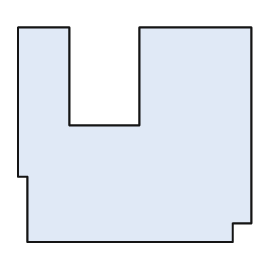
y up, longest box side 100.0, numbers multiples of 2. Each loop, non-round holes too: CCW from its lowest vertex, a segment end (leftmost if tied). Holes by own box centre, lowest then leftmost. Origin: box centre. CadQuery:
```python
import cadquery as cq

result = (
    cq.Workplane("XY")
    .moveTo(-46.0, -46.0)
    .lineTo(42.0, -46.0)
    .lineTo(42.0, -38.0)
    .lineTo(50.0, -38.0)
    .lineTo(50.0, 46.0)
    .lineTo(2.0, 46.0)
    .lineTo(2.0, 4.0)
    .lineTo(-28.0, 4.0)
    .lineTo(-28.0, 46.0)
    .lineTo(-50.0, 46.0)
    .lineTo(-50.0, -18.0)
    .lineTo(-46.0, -18.0)
    .close()
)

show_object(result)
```